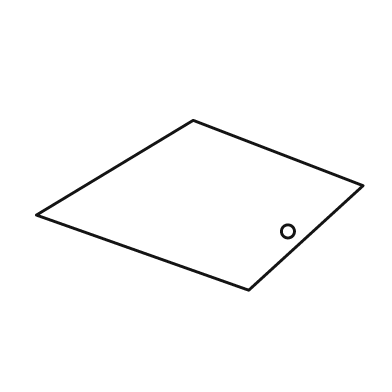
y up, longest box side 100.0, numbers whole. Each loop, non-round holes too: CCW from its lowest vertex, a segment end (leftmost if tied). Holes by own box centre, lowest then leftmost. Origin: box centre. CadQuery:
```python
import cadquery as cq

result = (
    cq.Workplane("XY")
    .moveTo(15.0, -26.0)
    .lineTo(50.0, 6.0)
    .lineTo(-2.0, 26.0)
    .lineTo(-50.0, -3.0)
    .close()
    .moveTo(27.0, -8.0)
    .circle(2.0)
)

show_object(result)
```